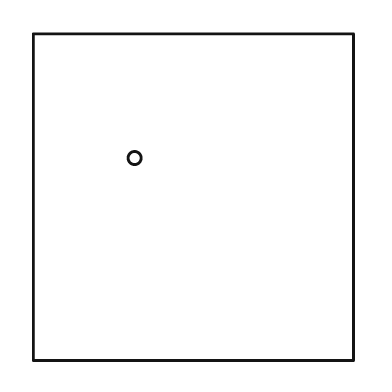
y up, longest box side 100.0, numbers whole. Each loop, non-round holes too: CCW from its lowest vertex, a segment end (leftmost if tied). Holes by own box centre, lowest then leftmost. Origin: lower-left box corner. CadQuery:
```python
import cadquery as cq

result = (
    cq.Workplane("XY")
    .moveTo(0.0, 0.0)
    .lineTo(98.0, 0.0)
    .lineTo(98.0, 100.0)
    .lineTo(0.0, 100.0)
    .close()
    .moveTo(31.0, 62.0)
    .circle(2.0)
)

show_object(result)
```